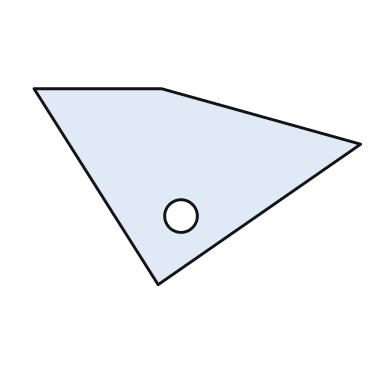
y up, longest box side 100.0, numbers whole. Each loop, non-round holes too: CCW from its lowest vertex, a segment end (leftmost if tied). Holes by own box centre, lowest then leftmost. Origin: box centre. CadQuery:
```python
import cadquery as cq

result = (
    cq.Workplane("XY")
    .moveTo(-12.0, -30.0)
    .lineTo(50.0, 13.0)
    .lineTo(-11.0, 30.0)
    .lineTo(-50.0, 30.0)
    .close()
    .moveTo(-5.0, -9.0)
    .circle(5.0)
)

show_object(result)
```